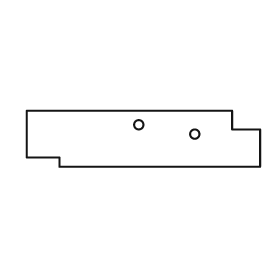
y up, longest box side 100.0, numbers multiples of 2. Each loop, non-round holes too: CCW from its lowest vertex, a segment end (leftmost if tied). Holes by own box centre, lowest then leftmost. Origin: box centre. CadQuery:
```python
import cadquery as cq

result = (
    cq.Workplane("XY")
    .moveTo(-36.0, -12.0)
    .lineTo(50.0, -12.0)
    .lineTo(50.0, 4.0)
    .lineTo(38.0, 4.0)
    .lineTo(38.0, 12.0)
    .lineTo(-50.0, 12.0)
    .lineTo(-50.0, -8.0)
    .lineTo(-36.0, -8.0)
    .close()
    .moveTo(22.0, 2.0)
    .circle(2.0)
    .moveTo(-2.0, 6.0)
    .circle(2.0)
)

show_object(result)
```